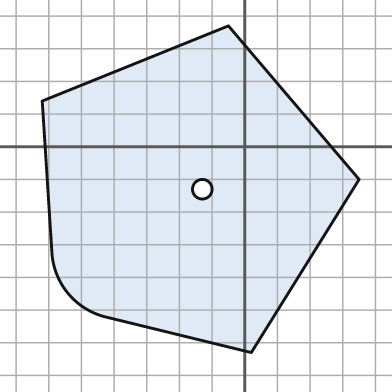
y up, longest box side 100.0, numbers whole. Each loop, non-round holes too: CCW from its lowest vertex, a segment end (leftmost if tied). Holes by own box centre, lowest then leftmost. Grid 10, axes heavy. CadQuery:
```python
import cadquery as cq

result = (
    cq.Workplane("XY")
    .moveTo(2.0, -63.0)
    .lineTo(35.0, -10.0)
    .lineTo(-5.0, 37.0)
    .lineTo(-62.0, 14.0)
    .lineTo(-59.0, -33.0)
    .threePointArc((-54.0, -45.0), (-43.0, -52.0))
    .close()
    .moveTo(-13.0, -13.0)
    .circle(3.0)
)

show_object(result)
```